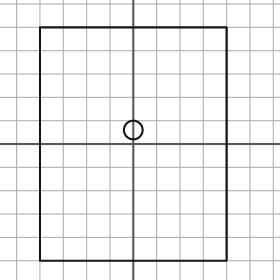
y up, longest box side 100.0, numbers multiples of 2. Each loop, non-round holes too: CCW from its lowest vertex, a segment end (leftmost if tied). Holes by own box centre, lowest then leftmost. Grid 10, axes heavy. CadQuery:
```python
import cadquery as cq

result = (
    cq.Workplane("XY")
    .moveTo(-40.0, -50.0)
    .lineTo(40.0, -50.0)
    .lineTo(40.0, 50.0)
    .lineTo(-40.0, 50.0)
    .close()
    .moveTo(0.0, 6.0)
    .circle(4.0)
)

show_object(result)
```